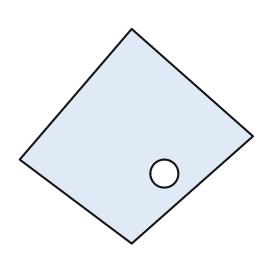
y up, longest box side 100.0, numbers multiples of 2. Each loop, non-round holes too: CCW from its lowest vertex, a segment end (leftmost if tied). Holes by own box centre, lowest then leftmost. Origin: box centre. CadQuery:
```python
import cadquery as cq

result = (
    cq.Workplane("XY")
    .moveTo(-2.0, -46.0)
    .lineTo(50.0, 0.0)
    .lineTo(-2.0, 46.0)
    .lineTo(-50.0, -10.0)
    .close()
    .moveTo(12.0, -16.0)
    .circle(6.0)
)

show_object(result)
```